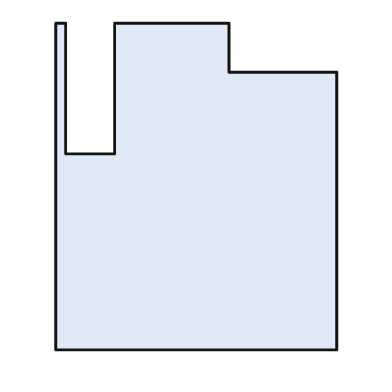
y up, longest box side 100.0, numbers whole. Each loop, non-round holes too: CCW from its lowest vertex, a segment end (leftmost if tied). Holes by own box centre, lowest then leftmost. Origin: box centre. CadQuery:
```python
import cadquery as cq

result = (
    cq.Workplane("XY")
    .moveTo(-43.0, -50.0)
    .lineTo(43.0, -50.0)
    .lineTo(43.0, 35.0)
    .lineTo(10.0, 35.0)
    .lineTo(10.0, 50.0)
    .lineTo(-25.0, 50.0)
    .lineTo(-25.0, 10.0)
    .lineTo(-40.0, 10.0)
    .lineTo(-40.0, 50.0)
    .lineTo(-43.0, 50.0)
    .close()
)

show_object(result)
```